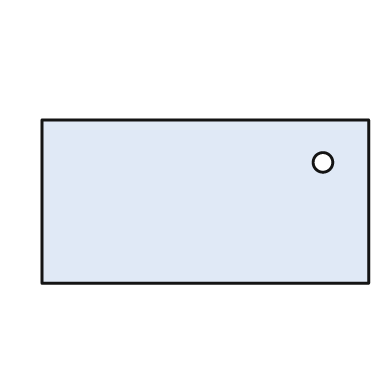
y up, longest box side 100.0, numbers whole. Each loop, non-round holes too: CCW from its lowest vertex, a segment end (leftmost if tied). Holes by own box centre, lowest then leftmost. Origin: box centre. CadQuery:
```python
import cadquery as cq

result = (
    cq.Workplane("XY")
    .moveTo(-50.0, -25.0)
    .lineTo(50.0, -25.0)
    .lineTo(50.0, 25.0)
    .lineTo(-50.0, 25.0)
    .close()
    .moveTo(36.0, 12.0)
    .circle(3.0)
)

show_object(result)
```